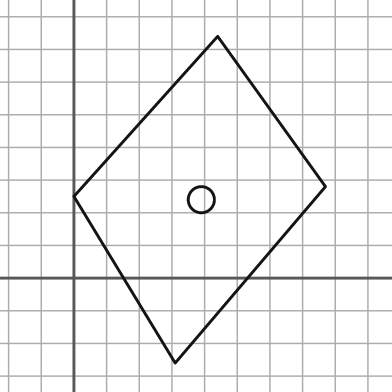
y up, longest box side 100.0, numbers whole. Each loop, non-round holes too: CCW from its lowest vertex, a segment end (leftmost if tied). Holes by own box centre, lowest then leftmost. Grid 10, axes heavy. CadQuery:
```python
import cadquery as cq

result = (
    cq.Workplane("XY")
    .moveTo(31.0, -26.0)
    .lineTo(77.0, 28.0)
    .lineTo(44.0, 74.0)
    .lineTo(0.0, 25.0)
    .close()
    .moveTo(39.0, 24.0)
    .circle(4.0)
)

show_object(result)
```